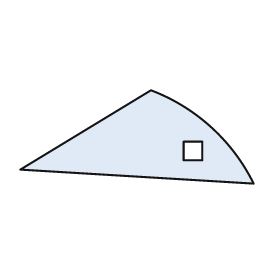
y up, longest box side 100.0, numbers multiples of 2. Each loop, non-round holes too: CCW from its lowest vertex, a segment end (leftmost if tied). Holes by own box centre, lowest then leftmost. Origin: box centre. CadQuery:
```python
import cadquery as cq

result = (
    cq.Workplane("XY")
    .moveTo(50.0, -20.0)
    .threePointArc((32.0, 4.0), (6.0, 20.0))
    .lineTo(-50.0, -14.0)
    .close()
    .moveTo(20.0, -10.0)
    .lineTo(28.0, -10.0)
    .lineTo(28.0, -2.0)
    .lineTo(20.0, -2.0)
    .close()
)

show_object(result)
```